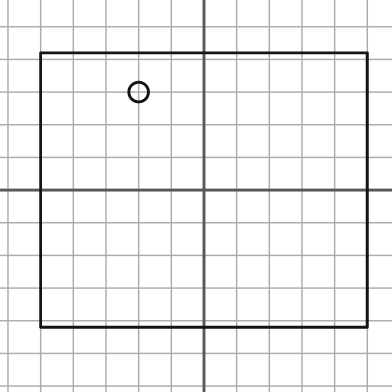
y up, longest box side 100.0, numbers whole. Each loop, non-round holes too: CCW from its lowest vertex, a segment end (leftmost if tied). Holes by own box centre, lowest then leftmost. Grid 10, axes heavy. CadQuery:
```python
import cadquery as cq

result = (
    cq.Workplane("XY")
    .moveTo(-50.0, -42.0)
    .lineTo(50.0, -42.0)
    .lineTo(50.0, 42.0)
    .lineTo(-50.0, 42.0)
    .close()
    .moveTo(-20.0, 30.0)
    .circle(3.0)
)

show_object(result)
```